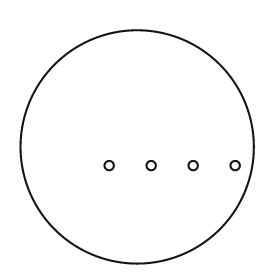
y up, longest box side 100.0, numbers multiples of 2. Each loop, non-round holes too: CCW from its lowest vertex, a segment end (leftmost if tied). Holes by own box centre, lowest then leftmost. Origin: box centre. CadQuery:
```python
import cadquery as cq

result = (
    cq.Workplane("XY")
    .moveTo(0.0, 0.0)
    .circle(50.0)
    .moveTo(-12.0, -8.0)
    .circle(2.0)
    .moveTo(6.0, -8.0)
    .circle(2.0)
    .moveTo(24.0, -8.0)
    .circle(2.0)
    .moveTo(42.0, -8.0)
    .circle(2.0)
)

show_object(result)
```